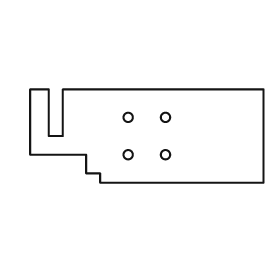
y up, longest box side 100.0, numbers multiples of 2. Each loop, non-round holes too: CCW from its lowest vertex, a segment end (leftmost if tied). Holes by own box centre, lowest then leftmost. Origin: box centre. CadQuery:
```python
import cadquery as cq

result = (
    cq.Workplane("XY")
    .moveTo(-20.0, -20.0)
    .lineTo(50.0, -20.0)
    .lineTo(50.0, 20.0)
    .lineTo(-36.0, 20.0)
    .lineTo(-36.0, 0.0)
    .lineTo(-42.0, 0.0)
    .lineTo(-42.0, 20.0)
    .lineTo(-50.0, 20.0)
    .lineTo(-50.0, -8.0)
    .lineTo(-26.0, -8.0)
    .lineTo(-26.0, -16.0)
    .lineTo(-20.0, -16.0)
    .close()
    .moveTo(-8.0, -8.0)
    .circle(2.0)
    .moveTo(8.0, -8.0)
    .circle(2.0)
    .moveTo(-8.0, 8.0)
    .circle(2.0)
    .moveTo(8.0, 8.0)
    .circle(2.0)
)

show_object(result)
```